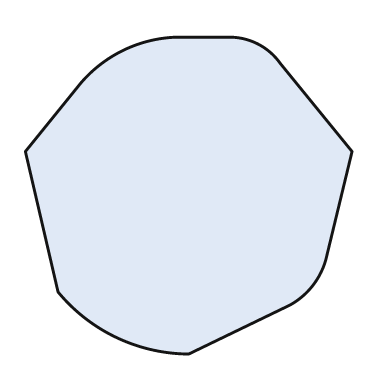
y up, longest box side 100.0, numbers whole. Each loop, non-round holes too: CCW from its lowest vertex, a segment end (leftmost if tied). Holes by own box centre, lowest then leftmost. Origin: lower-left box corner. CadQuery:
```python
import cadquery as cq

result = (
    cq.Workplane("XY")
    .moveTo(50.0, 0.0)
    .lineTo(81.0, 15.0)
    .threePointArc((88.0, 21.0), (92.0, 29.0))
    .lineTo(100.0, 62.0)
    .lineTo(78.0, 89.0)
    .threePointArc((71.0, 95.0), (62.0, 97.0))
    .lineTo(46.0, 97.0)
    .threePointArc((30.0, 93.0), (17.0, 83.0))
    .lineTo(0.0, 62.0)
    .lineTo(10.0, 19.0)
    .threePointArc((28.0, 5.0), (50.0, 0.0))
    .close()
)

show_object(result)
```